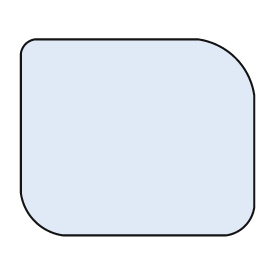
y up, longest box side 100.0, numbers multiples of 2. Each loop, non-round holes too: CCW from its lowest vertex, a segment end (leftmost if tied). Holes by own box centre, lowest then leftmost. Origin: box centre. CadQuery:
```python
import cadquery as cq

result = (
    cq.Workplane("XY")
    .moveTo(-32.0, -42.0)
    .lineTo(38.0, -42.0)
    .threePointArc((46.0, -38.0), (50.0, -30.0))
    .lineTo(50.0, 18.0)
    .threePointArc((42.0, 34.0), (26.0, 42.0))
    .lineTo(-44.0, 42.0)
    .threePointArc((-48.0, 40.0), (-50.0, 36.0))
    .lineTo(-50.0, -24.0)
    .threePointArc((-44.0, -36.0), (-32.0, -42.0))
    .close()
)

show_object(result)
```